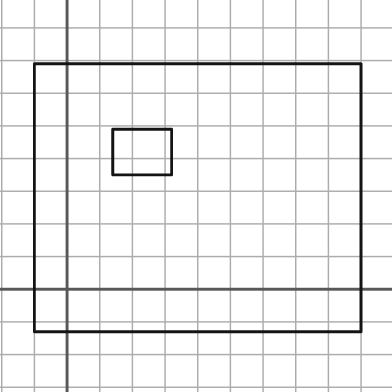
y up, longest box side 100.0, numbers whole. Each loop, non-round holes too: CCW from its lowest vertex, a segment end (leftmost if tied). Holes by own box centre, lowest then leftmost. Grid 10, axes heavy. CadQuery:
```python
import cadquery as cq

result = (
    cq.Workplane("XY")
    .moveTo(-10.0, -13.0)
    .lineTo(90.0, -13.0)
    .lineTo(90.0, 69.0)
    .lineTo(-10.0, 69.0)
    .close()
    .moveTo(14.0, 35.0)
    .lineTo(32.0, 35.0)
    .lineTo(32.0, 49.0)
    .lineTo(14.0, 49.0)
    .close()
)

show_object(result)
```